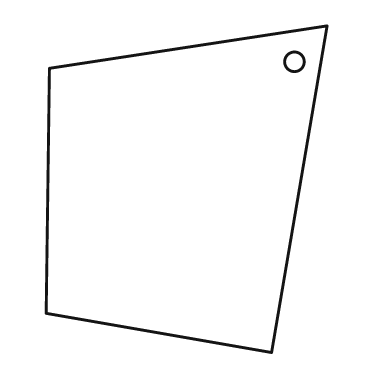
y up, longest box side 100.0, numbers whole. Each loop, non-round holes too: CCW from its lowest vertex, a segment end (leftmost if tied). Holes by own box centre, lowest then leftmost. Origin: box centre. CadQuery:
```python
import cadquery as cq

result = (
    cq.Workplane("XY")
    .moveTo(26.0, -50.0)
    .lineTo(43.0, 50.0)
    .lineTo(-42.0, 37.0)
    .lineTo(-43.0, -38.0)
    .close()
    .moveTo(33.0, 39.0)
    .circle(3.0)
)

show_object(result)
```